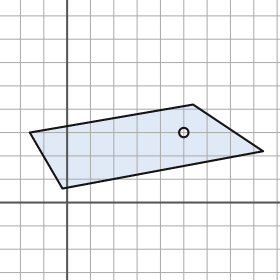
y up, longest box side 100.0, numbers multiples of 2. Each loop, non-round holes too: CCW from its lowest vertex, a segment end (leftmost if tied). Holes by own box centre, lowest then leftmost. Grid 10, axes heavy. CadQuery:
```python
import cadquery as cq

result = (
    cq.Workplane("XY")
    .moveTo(-2.0, 6.0)
    .lineTo(84.0, 22.0)
    .lineTo(54.0, 42.0)
    .lineTo(-16.0, 30.0)
    .close()
    .moveTo(50.0, 30.0)
    .circle(2.0)
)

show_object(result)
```